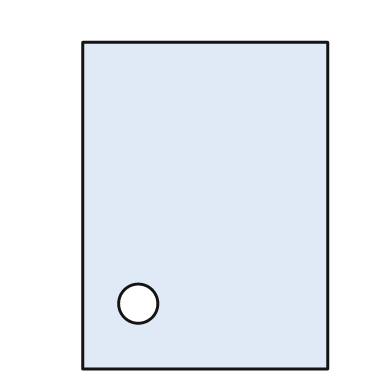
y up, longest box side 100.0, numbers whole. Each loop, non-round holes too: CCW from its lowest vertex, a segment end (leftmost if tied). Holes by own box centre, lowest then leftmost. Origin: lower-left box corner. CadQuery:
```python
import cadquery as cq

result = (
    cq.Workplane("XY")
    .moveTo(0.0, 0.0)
    .lineTo(75.0, 0.0)
    .lineTo(75.0, 100.0)
    .lineTo(0.0, 100.0)
    .close()
    .moveTo(17.0, 20.0)
    .circle(6.0)
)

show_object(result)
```